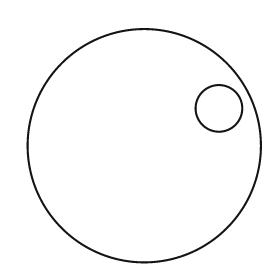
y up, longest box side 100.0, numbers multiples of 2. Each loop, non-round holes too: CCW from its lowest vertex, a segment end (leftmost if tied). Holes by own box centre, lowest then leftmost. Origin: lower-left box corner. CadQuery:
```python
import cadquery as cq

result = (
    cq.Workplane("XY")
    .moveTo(50.0, 50.0)
    .circle(50.0)
    .moveTo(82.0, 66.0)
    .circle(10.0)
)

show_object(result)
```